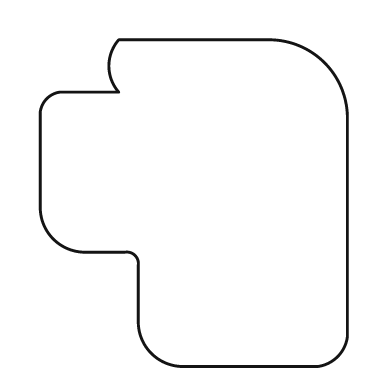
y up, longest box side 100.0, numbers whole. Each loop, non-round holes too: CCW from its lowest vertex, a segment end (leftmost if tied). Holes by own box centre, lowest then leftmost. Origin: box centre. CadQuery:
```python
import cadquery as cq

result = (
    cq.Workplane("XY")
    .moveTo(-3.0, -50.0)
    .lineTo(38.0, -50.0)
    .threePointArc((44.0, -47.0), (47.0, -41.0))
    .lineTo(47.0, 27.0)
    .threePointArc((40.0, 43.0), (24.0, 50.0))
    .lineTo(-23.0, 50.0)
    .threePointArc((-26.0, 42.0), (-23.0, 34.0))
    .lineTo(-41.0, 34.0)
    .threePointArc((-45.0, 32.0), (-47.0, 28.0))
    .lineTo(-47.0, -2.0)
    .threePointArc((-43.0, -11.0), (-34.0, -15.0))
    .lineTo(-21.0, -15.0)
    .threePointArc((-18.0, -16.0), (-17.0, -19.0))
    .lineTo(-17.0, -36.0)
    .threePointArc((-13.0, -46.0), (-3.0, -50.0))
    .close()
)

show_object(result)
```